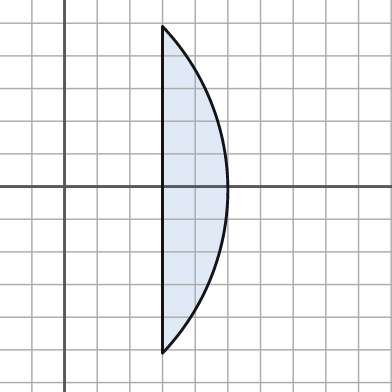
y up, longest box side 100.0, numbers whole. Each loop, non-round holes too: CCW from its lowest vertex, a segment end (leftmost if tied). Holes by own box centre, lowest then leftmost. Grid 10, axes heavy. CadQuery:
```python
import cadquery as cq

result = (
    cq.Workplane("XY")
    .moveTo(30.0, -51.0)
    .threePointArc((50.0, -1.0), (30.0, 49.0))
    .close()
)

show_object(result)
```